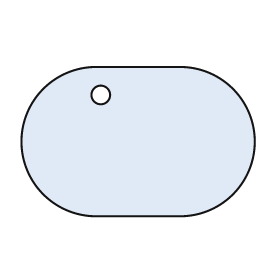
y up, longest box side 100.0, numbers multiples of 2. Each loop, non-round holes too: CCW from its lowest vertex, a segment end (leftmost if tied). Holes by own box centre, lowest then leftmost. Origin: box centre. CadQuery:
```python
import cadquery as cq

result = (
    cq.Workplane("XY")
    .moveTo(-18.0, -32.0)
    .lineTo(18.0, -32.0)
    .threePointArc((50.0, 0.0), (18.0, 32.0))
    .lineTo(-18.0, 32.0)
    .threePointArc((-50.0, 0.0), (-18.0, -32.0))
    .close()
    .moveTo(-16.0, 20.0)
    .circle(4.0)
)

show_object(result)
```